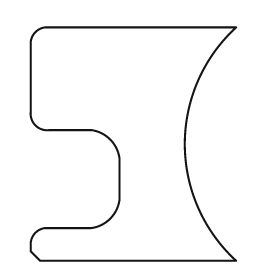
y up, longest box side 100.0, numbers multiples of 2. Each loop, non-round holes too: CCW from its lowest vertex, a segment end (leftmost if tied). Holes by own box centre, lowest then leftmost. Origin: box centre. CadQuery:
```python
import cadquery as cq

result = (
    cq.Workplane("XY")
    .moveTo(-40.0, -50.0)
    .lineTo(44.0, -50.0)
    .threePointArc((22.0, 0.0), (44.0, 50.0))
    .lineTo(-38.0, 50.0)
    .threePointArc((-42.0, 48.0), (-44.0, 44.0))
    .lineTo(-44.0, 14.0)
    .threePointArc((-42.0, 8.0), (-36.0, 6.0))
    .lineTo(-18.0, 6.0)
    .threePointArc((-10.0, 2.0), (-6.0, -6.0))
    .lineTo(-6.0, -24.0)
    .threePointArc((-10.0, -32.0), (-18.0, -36.0))
    .lineTo(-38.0, -36.0)
    .threePointArc((-42.0, -38.0), (-44.0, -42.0))
    .lineTo(-44.0, -46.0)
    .close()
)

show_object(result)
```